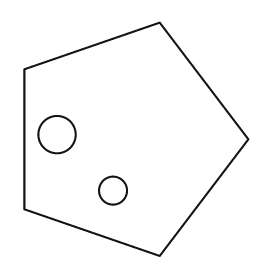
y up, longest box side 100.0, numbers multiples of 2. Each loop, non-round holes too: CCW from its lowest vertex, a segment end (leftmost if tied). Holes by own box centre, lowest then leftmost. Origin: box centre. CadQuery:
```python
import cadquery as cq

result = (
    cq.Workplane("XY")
    .moveTo(10.0, -50.0)
    .lineTo(48.0, 0.0)
    .lineTo(10.0, 50.0)
    .lineTo(-48.0, 30.0)
    .lineTo(-48.0, -30.0)
    .close()
    .moveTo(-10.0, -22.0)
    .circle(6.0)
    .moveTo(-34.0, 2.0)
    .circle(8.0)
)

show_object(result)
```